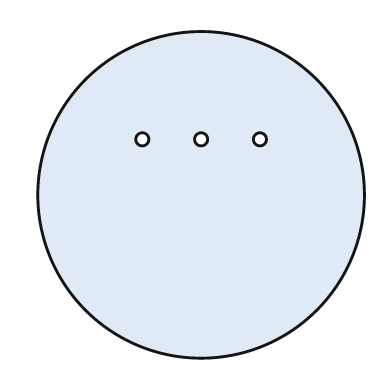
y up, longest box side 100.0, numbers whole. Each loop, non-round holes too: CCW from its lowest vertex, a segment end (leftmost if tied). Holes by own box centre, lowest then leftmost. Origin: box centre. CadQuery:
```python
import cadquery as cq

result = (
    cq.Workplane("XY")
    .moveTo(0.0, 0.0)
    .circle(50.0)
    .moveTo(-18.0, 17.0)
    .circle(2.0)
    .moveTo(0.0, 17.0)
    .circle(2.0)
    .moveTo(18.0, 17.0)
    .circle(2.0)
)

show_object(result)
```